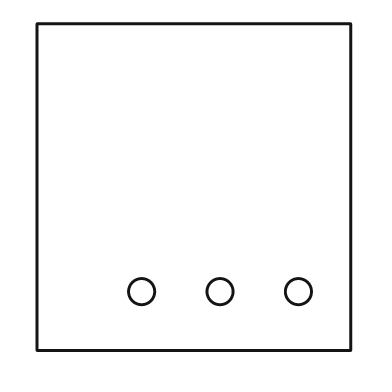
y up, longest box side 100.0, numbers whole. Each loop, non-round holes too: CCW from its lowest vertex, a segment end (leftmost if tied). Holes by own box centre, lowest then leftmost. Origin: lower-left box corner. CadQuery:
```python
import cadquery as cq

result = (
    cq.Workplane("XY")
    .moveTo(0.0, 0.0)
    .lineTo(96.0, 0.0)
    .lineTo(96.0, 100.0)
    .lineTo(0.0, 100.0)
    .close()
    .moveTo(32.0, 18.0)
    .circle(4.0)
    .moveTo(56.0, 18.0)
    .circle(4.0)
    .moveTo(80.0, 18.0)
    .circle(4.0)
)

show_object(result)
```